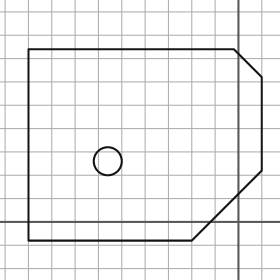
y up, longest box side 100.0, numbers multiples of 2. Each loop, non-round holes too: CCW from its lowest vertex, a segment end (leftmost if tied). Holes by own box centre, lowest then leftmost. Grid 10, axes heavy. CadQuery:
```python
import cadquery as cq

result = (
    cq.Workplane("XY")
    .moveTo(-90.0, -8.0)
    .lineTo(-20.0, -8.0)
    .lineTo(10.0, 22.0)
    .lineTo(10.0, 62.0)
    .lineTo(-2.0, 74.0)
    .lineTo(-90.0, 74.0)
    .close()
    .moveTo(-56.0, 26.0)
    .circle(6.0)
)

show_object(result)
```